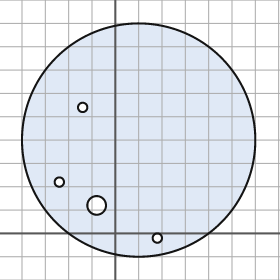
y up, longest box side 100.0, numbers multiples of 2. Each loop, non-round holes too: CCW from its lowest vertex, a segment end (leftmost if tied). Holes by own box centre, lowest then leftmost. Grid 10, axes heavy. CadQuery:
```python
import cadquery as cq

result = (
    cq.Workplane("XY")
    .moveTo(10.0, 40.0)
    .circle(50.0)
    .moveTo(18.0, -2.0)
    .circle(2.0)
    .moveTo(-8.0, 12.0)
    .circle(4.0)
    .moveTo(-24.0, 22.0)
    .circle(2.0)
    .moveTo(-14.0, 54.0)
    .circle(2.0)
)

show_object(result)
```